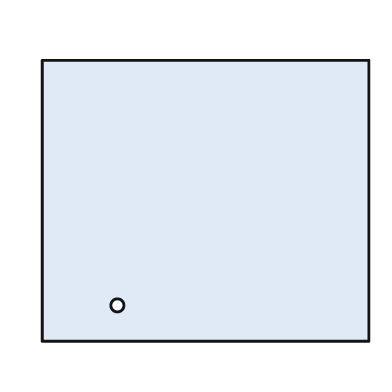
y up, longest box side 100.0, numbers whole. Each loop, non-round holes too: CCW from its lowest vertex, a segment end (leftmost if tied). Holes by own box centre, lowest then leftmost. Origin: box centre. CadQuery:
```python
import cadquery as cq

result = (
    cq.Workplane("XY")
    .moveTo(-50.0, -43.0)
    .lineTo(50.0, -43.0)
    .lineTo(50.0, 43.0)
    .lineTo(-50.0, 43.0)
    .close()
    .moveTo(-27.0, -32.0)
    .circle(2.0)
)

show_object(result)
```